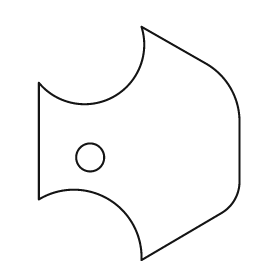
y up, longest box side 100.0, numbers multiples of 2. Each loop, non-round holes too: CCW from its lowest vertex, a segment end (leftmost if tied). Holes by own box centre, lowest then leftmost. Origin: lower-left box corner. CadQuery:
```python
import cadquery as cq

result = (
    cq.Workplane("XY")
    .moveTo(44.0, 0.0)
    .lineTo(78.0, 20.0)
    .threePointArc((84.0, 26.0), (86.0, 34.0))
    .lineTo(86.0, 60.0)
    .threePointArc((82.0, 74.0), (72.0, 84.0))
    .lineTo(44.0, 100.0)
    .threePointArc((32.0, 70.0), (0.0, 76.0))
    .lineTo(0.0, 26.0)
    .threePointArc((30.0, 26.0), (44.0, 0.0))
    .close()
    .moveTo(22.0, 44.0)
    .circle(6.0)
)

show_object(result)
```